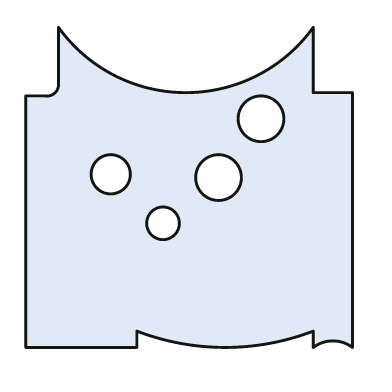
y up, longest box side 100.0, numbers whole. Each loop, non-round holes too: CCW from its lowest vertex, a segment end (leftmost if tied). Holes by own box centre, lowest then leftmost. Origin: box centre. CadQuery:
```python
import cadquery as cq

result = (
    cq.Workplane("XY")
    .moveTo(-50.0, -49.0)
    .lineTo(-16.0, -49.0)
    .lineTo(-16.0, -44.0)
    .threePointArc((11.0, -49.0), (38.0, -44.0))
    .lineTo(38.0, -49.0)
    .threePointArc((44.0, -47.0), (50.0, -49.0))
    .lineTo(50.0, 29.0)
    .lineTo(38.0, 29.0)
    .lineTo(38.0, 49.0)
    .threePointArc((-1.0, 29.0), (-40.0, 49.0))
    .lineTo(-40.0, 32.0)
    .threePointArc((-41.0, 29.0), (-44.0, 28.0))
    .lineTo(-50.0, 28.0)
    .close()
    .moveTo(-8.0, -11.0)
    .circle(5.0)
    .moveTo(9.0, 3.0)
    .circle(7.0)
    .moveTo(-24.0, 4.0)
    .circle(6.0)
    .moveTo(22.0, 21.0)
    .circle(7.0)
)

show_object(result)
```